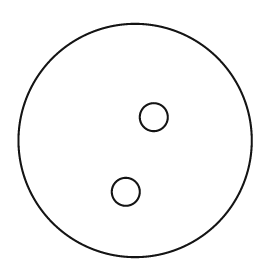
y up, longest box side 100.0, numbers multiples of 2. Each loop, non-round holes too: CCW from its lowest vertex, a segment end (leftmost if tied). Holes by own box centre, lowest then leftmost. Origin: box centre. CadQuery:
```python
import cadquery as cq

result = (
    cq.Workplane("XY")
    .moveTo(0.0, 0.0)
    .circle(50.0)
    .moveTo(-4.0, -22.0)
    .circle(6.0)
    .moveTo(8.0, 10.0)
    .circle(6.0)
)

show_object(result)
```